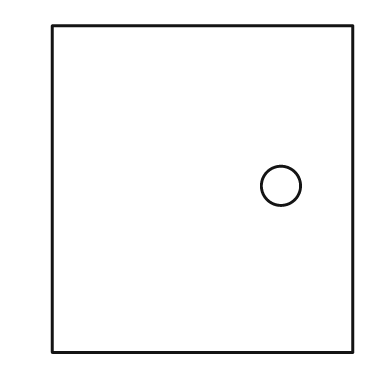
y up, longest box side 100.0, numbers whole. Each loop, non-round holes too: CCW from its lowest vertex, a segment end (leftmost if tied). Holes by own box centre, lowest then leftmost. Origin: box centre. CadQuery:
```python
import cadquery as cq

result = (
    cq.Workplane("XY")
    .moveTo(-46.0, -50.0)
    .lineTo(46.0, -50.0)
    .lineTo(46.0, 50.0)
    .lineTo(-46.0, 50.0)
    .close()
    .moveTo(24.0, 1.0)
    .circle(6.0)
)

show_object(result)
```